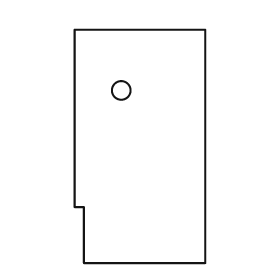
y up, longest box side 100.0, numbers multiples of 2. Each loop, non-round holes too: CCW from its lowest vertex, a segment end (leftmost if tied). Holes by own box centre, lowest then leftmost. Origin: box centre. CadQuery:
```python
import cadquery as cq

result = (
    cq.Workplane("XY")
    .moveTo(-24.0, -50.0)
    .lineTo(28.0, -50.0)
    .lineTo(28.0, 50.0)
    .lineTo(-28.0, 50.0)
    .lineTo(-28.0, -26.0)
    .lineTo(-24.0, -26.0)
    .close()
    .moveTo(-8.0, 24.0)
    .circle(4.0)
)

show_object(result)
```